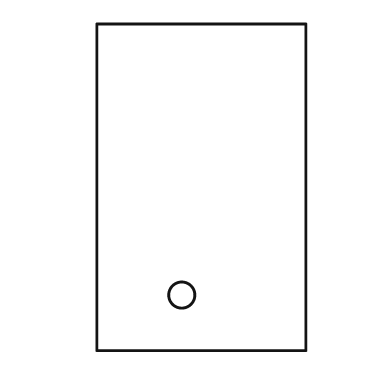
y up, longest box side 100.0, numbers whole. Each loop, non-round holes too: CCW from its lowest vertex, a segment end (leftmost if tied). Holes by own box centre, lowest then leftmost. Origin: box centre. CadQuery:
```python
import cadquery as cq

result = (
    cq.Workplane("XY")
    .moveTo(-32.0, -50.0)
    .lineTo(32.0, -50.0)
    .lineTo(32.0, 50.0)
    .lineTo(-32.0, 50.0)
    .close()
    .moveTo(-6.0, -33.0)
    .circle(4.0)
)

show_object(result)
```